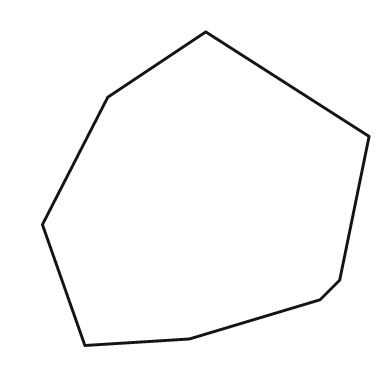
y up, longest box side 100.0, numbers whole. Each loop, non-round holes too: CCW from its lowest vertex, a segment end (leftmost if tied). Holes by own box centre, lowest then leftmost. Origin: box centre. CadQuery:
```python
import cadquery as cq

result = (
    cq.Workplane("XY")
    .moveTo(-37.0, -48.0)
    .lineTo(-5.0, -46.0)
    .lineTo(35.0, -34.0)
    .lineTo(41.0, -28.0)
    .lineTo(50.0, 16.0)
    .lineTo(0.0, 48.0)
    .lineTo(-30.0, 28.0)
    .lineTo(-50.0, -11.0)
    .close()
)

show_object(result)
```